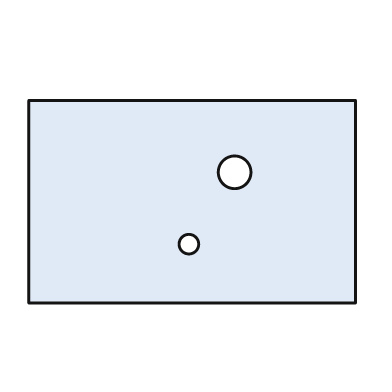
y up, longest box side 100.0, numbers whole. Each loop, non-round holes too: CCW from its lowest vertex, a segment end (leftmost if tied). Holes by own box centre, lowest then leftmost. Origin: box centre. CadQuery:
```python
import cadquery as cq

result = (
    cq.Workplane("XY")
    .moveTo(-50.0, -31.0)
    .lineTo(50.0, -31.0)
    .lineTo(50.0, 31.0)
    .lineTo(-50.0, 31.0)
    .close()
    .moveTo(-1.0, -13.0)
    .circle(3.0)
    .moveTo(13.0, 9.0)
    .circle(5.0)
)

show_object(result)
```